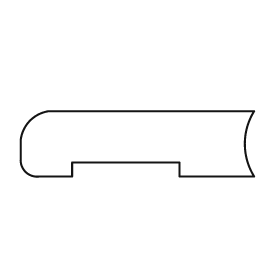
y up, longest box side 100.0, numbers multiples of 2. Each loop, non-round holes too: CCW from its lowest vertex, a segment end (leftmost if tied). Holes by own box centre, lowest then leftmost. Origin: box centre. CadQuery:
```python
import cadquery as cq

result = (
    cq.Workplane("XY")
    .moveTo(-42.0, -14.0)
    .lineTo(-28.0, -14.0)
    .lineTo(-28.0, -8.0)
    .lineTo(18.0, -8.0)
    .lineTo(18.0, -14.0)
    .lineTo(50.0, -14.0)
    .threePointArc((46.0, 0.0), (50.0, 14.0))
    .lineTo(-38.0, 14.0)
    .threePointArc((-46.0, 10.0), (-50.0, 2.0))
    .lineTo(-50.0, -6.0)
    .threePointArc((-48.0, -12.0), (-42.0, -14.0))
    .close()
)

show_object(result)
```